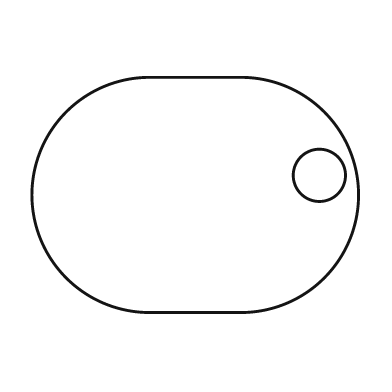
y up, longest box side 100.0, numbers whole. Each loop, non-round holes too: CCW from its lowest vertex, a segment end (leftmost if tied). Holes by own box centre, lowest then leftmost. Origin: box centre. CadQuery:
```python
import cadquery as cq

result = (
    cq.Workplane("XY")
    .moveTo(-14.0, -36.0)
    .lineTo(14.0, -36.0)
    .threePointArc((50.0, 0.0), (14.0, 36.0))
    .lineTo(-14.0, 36.0)
    .threePointArc((-50.0, 0.0), (-14.0, -36.0))
    .close()
    .moveTo(38.0, 6.0)
    .circle(8.0)
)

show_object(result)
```